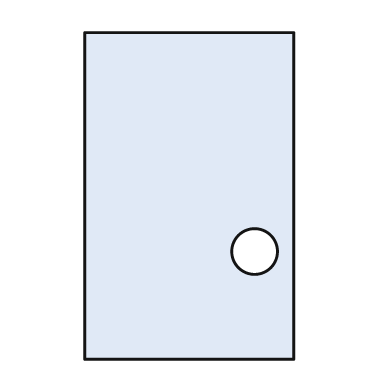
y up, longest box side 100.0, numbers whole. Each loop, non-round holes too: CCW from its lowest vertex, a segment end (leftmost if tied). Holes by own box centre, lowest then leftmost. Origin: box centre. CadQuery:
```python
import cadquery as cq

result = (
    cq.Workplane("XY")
    .moveTo(-32.0, -50.0)
    .lineTo(32.0, -50.0)
    .lineTo(32.0, 50.0)
    .lineTo(-32.0, 50.0)
    .close()
    .moveTo(20.0, -17.0)
    .circle(7.0)
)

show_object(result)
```